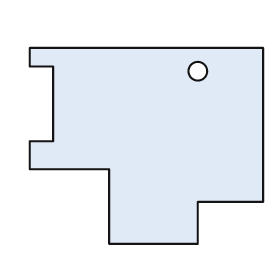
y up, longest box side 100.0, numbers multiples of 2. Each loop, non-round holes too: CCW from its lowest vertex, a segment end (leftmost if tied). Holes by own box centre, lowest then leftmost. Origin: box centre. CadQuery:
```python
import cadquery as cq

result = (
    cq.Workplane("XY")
    .moveTo(-16.0, -42.0)
    .lineTo(22.0, -42.0)
    .lineTo(22.0, -24.0)
    .lineTo(50.0, -24.0)
    .lineTo(50.0, 42.0)
    .lineTo(-50.0, 42.0)
    .lineTo(-50.0, 34.0)
    .lineTo(-40.0, 34.0)
    .lineTo(-40.0, 2.0)
    .lineTo(-50.0, 2.0)
    .lineTo(-50.0, -10.0)
    .lineTo(-16.0, -10.0)
    .close()
    .moveTo(22.0, 32.0)
    .circle(4.0)
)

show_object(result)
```